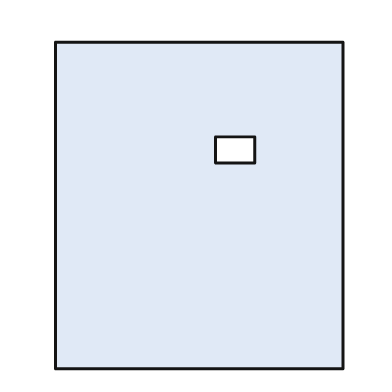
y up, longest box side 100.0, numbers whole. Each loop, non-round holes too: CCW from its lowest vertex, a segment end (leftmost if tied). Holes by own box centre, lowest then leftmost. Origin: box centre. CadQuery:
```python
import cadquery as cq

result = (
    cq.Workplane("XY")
    .moveTo(-44.0, -50.0)
    .lineTo(44.0, -50.0)
    .lineTo(44.0, 50.0)
    .lineTo(-44.0, 50.0)
    .close()
    .moveTo(5.0, 13.0)
    .lineTo(17.0, 13.0)
    .lineTo(17.0, 21.0)
    .lineTo(5.0, 21.0)
    .close()
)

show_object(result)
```